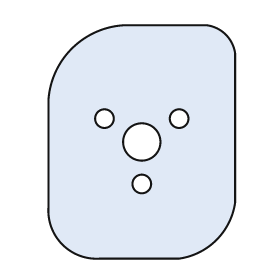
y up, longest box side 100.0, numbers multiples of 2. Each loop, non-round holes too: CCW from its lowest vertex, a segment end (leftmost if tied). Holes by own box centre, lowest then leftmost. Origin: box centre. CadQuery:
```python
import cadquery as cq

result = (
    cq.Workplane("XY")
    .moveTo(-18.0, -50.0)
    .lineTo(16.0, -50.0)
    .threePointArc((32.0, -42.0), (40.0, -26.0))
    .lineTo(40.0, 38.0)
    .threePointArc((36.0, 46.0), (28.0, 50.0))
    .lineTo(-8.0, 50.0)
    .threePointArc((-30.0, 40.0), (-40.0, 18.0))
    .lineTo(-40.0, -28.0)
    .threePointArc((-34.0, -44.0), (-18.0, -50.0))
    .close()
    .moveTo(0.0, -18.0)
    .circle(4.0)
    .moveTo(0.0, 0.0)
    .circle(8.0)
    .moveTo(-16.0, 10.0)
    .circle(4.0)
    .moveTo(16.0, 10.0)
    .circle(4.0)
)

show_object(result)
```